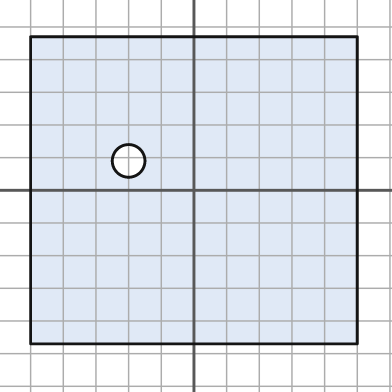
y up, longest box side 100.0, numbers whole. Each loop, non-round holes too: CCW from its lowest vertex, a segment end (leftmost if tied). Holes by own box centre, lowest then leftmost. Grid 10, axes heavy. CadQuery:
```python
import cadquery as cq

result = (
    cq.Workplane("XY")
    .moveTo(-50.0, -47.0)
    .lineTo(50.0, -47.0)
    .lineTo(50.0, 47.0)
    .lineTo(-50.0, 47.0)
    .close()
    .moveTo(-20.0, 9.0)
    .circle(5.0)
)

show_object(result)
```